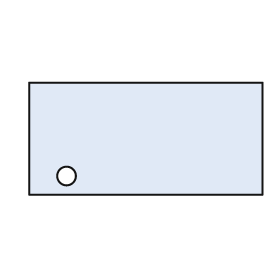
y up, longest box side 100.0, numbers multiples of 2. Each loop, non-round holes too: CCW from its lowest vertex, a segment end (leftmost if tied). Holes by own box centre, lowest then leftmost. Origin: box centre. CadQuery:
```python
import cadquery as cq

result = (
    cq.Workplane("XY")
    .moveTo(-50.0, -24.0)
    .lineTo(50.0, -24.0)
    .lineTo(50.0, 24.0)
    .lineTo(-50.0, 24.0)
    .close()
    .moveTo(-34.0, -16.0)
    .circle(4.0)
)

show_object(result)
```